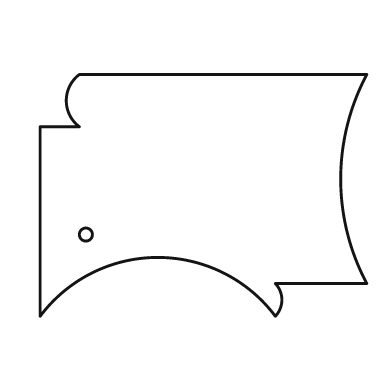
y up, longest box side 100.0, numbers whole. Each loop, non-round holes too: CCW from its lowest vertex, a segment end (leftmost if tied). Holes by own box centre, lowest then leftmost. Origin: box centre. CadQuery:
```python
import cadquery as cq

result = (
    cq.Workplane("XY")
    .moveTo(-50.0, -37.0)
    .threePointArc((-14.0, -19.0), (22.0, -37.0))
    .threePointArc((24.0, -32.0), (22.0, -27.0))
    .lineTo(50.0, -27.0)
    .threePointArc((42.0, 5.0), (50.0, 37.0))
    .lineTo(-38.0, 37.0)
    .threePointArc((-42.0, 29.0), (-38.0, 21.0))
    .lineTo(-50.0, 21.0)
    .close()
    .moveTo(-36.0, -12.0)
    .circle(2.0)
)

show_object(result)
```